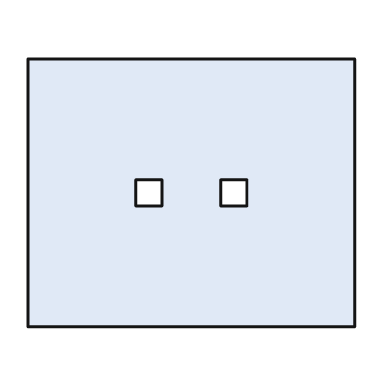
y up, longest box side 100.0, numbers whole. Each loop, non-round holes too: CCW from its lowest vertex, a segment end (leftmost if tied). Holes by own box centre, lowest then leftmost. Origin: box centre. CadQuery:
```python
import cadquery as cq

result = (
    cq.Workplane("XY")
    .moveTo(-50.0, -41.0)
    .lineTo(50.0, -41.0)
    .lineTo(50.0, 41.0)
    .lineTo(-50.0, 41.0)
    .close()
    .moveTo(-17.0, -4.0)
    .lineTo(-9.0, -4.0)
    .lineTo(-9.0, 4.0)
    .lineTo(-17.0, 4.0)
    .close()
    .moveTo(9.0, -4.0)
    .lineTo(17.0, -4.0)
    .lineTo(17.0, 4.0)
    .lineTo(9.0, 4.0)
    .close()
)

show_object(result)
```